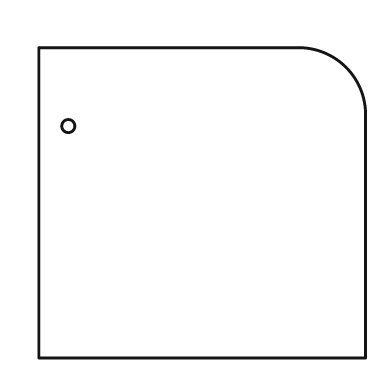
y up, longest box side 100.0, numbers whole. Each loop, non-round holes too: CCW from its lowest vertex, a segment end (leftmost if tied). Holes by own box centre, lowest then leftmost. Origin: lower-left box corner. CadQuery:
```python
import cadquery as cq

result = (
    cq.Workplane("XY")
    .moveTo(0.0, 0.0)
    .lineTo(100.0, 0.0)
    .lineTo(100.0, 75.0)
    .threePointArc((94.0, 89.0), (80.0, 95.0))
    .lineTo(0.0, 95.0)
    .close()
    .moveTo(9.0, 71.0)
    .circle(2.0)
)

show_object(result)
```